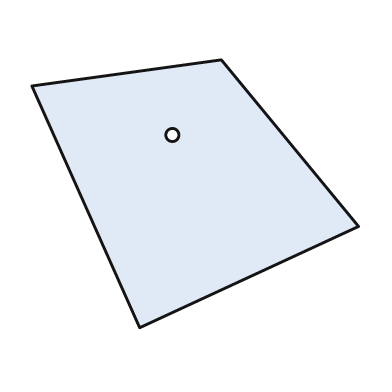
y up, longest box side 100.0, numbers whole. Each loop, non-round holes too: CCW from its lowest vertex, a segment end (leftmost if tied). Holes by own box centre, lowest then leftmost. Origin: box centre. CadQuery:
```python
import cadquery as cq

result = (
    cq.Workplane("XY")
    .moveTo(-17.0, -41.0)
    .lineTo(50.0, -10.0)
    .lineTo(8.0, 41.0)
    .lineTo(-50.0, 33.0)
    .close()
    .moveTo(-7.0, 18.0)
    .circle(2.0)
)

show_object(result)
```